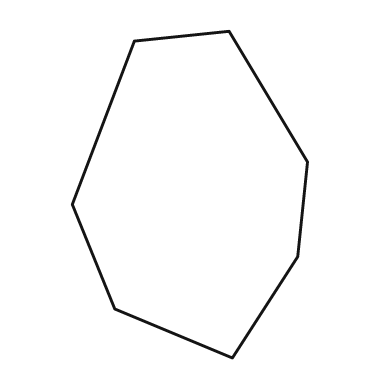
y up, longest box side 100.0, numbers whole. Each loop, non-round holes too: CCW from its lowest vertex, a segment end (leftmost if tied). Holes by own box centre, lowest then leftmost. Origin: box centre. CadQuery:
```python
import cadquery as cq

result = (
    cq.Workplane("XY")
    .moveTo(13.0, -50.0)
    .lineTo(33.0, -19.0)
    .lineTo(36.0, 10.0)
    .lineTo(12.0, 50.0)
    .lineTo(-17.0, 47.0)
    .lineTo(-36.0, -3.0)
    .lineTo(-23.0, -35.0)
    .close()
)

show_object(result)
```